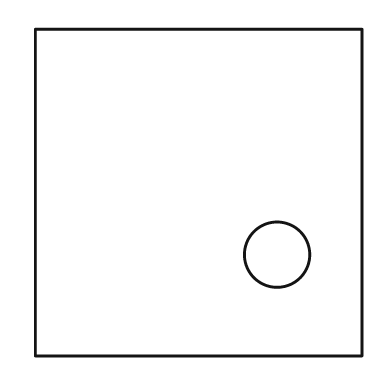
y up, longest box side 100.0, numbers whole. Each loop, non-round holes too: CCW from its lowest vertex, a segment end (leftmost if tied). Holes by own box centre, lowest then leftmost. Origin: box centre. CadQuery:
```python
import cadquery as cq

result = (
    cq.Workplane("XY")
    .moveTo(-50.0, -50.0)
    .lineTo(50.0, -50.0)
    .lineTo(50.0, 50.0)
    .lineTo(-50.0, 50.0)
    .close()
    .moveTo(24.0, -19.0)
    .circle(10.0)
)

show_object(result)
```